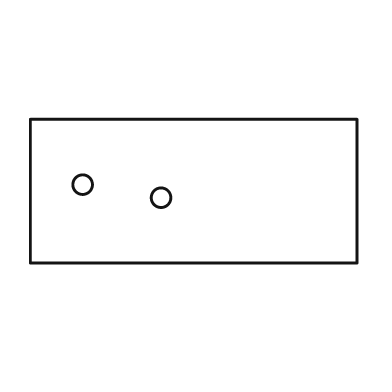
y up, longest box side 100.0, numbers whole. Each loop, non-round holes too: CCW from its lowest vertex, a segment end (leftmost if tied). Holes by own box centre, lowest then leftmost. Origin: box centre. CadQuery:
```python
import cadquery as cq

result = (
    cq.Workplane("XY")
    .moveTo(-50.0, -22.0)
    .lineTo(50.0, -22.0)
    .lineTo(50.0, 22.0)
    .lineTo(-50.0, 22.0)
    .close()
    .moveTo(-10.0, -2.0)
    .circle(3.0)
    .moveTo(-34.0, 2.0)
    .circle(3.0)
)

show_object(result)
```